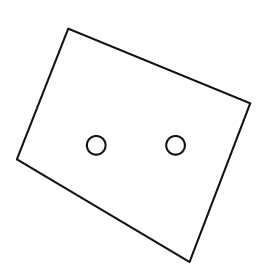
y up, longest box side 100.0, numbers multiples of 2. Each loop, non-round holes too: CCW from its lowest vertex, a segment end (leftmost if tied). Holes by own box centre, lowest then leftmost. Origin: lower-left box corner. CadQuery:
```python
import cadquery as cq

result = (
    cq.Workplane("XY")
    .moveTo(74.0, 0.0)
    .lineTo(100.0, 68.0)
    .lineTo(22.0, 100.0)
    .lineTo(0.0, 44.0)
    .close()
    .moveTo(34.0, 50.0)
    .circle(4.0)
    .moveTo(68.0, 50.0)
    .circle(4.0)
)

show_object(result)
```